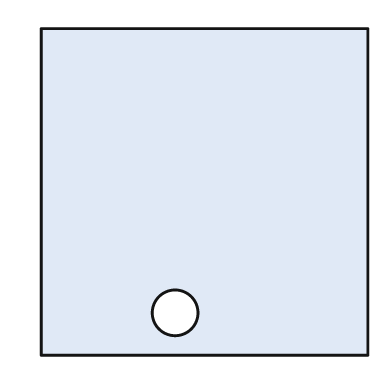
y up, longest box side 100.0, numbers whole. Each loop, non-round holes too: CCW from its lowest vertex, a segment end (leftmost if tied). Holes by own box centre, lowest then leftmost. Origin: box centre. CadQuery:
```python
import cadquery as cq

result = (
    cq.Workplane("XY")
    .moveTo(-50.0, -50.0)
    .lineTo(50.0, -50.0)
    .lineTo(50.0, 50.0)
    .lineTo(-50.0, 50.0)
    .close()
    .moveTo(-9.0, -37.0)
    .circle(7.0)
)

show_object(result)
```